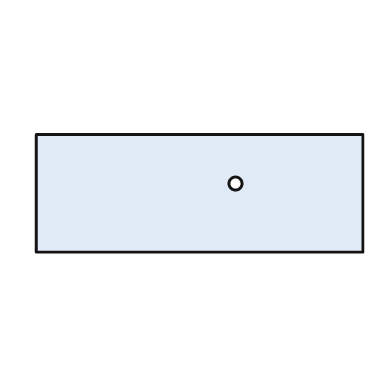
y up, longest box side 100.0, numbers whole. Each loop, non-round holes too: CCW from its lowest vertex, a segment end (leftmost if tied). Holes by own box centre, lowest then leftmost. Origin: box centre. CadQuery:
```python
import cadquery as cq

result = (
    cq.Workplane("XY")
    .moveTo(-50.0, -18.0)
    .lineTo(50.0, -18.0)
    .lineTo(50.0, 18.0)
    .lineTo(-50.0, 18.0)
    .close()
    .moveTo(11.0, 3.0)
    .circle(2.0)
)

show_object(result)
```